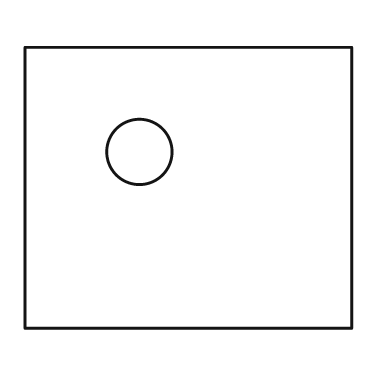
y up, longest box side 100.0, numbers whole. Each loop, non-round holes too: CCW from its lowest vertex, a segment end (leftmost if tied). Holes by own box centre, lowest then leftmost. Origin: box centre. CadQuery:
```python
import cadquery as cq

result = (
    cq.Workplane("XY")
    .moveTo(-50.0, -43.0)
    .lineTo(50.0, -43.0)
    .lineTo(50.0, 43.0)
    .lineTo(-50.0, 43.0)
    .close()
    .moveTo(-15.0, 11.0)
    .circle(10.0)
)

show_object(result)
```